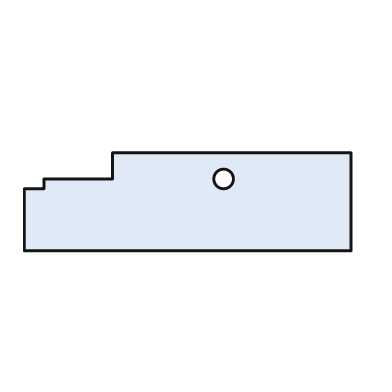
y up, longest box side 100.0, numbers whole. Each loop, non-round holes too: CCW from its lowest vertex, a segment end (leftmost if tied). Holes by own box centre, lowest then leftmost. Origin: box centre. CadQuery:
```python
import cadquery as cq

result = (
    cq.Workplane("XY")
    .moveTo(-50.0, -15.0)
    .lineTo(50.0, -15.0)
    .lineTo(50.0, 15.0)
    .lineTo(-23.0, 15.0)
    .lineTo(-23.0, 7.0)
    .lineTo(-44.0, 7.0)
    .lineTo(-44.0, 4.0)
    .lineTo(-50.0, 4.0)
    .close()
    .moveTo(11.0, 7.0)
    .circle(3.0)
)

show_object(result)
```